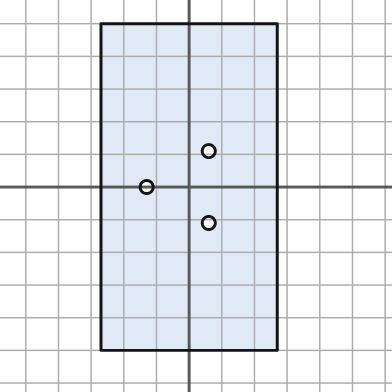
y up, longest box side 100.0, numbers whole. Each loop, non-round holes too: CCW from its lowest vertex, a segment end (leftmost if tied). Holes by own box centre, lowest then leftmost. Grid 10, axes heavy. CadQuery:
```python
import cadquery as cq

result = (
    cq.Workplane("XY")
    .moveTo(-27.0, -50.0)
    .lineTo(27.0, -50.0)
    .lineTo(27.0, 50.0)
    .lineTo(-27.0, 50.0)
    .close()
    .moveTo(6.0, -11.0)
    .circle(2.0)
    .moveTo(-13.0, 0.0)
    .circle(2.0)
    .moveTo(6.0, 11.0)
    .circle(2.0)
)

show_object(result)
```